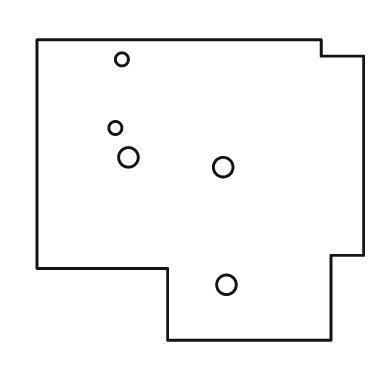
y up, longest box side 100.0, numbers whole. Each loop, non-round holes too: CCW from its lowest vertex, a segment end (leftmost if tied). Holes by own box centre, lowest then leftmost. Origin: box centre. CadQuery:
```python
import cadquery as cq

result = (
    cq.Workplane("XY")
    .moveTo(-10.0, -46.0)
    .lineTo(40.0, -46.0)
    .lineTo(40.0, -20.0)
    .lineTo(50.0, -20.0)
    .lineTo(50.0, 41.0)
    .lineTo(37.0, 41.0)
    .lineTo(37.0, 46.0)
    .lineTo(-50.0, 46.0)
    .lineTo(-50.0, -24.0)
    .lineTo(-10.0, -24.0)
    .close()
    .moveTo(8.0, -29.0)
    .circle(3.0)
    .moveTo(7.0, 7.0)
    .circle(3.0)
    .moveTo(-22.0, 10.0)
    .circle(3.0)
    .moveTo(-26.0, 19.0)
    .circle(2.0)
    .moveTo(-24.0, 40.0)
    .circle(2.0)
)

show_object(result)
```